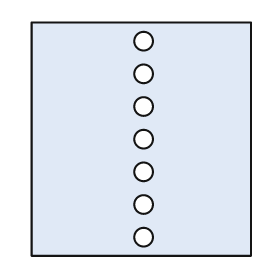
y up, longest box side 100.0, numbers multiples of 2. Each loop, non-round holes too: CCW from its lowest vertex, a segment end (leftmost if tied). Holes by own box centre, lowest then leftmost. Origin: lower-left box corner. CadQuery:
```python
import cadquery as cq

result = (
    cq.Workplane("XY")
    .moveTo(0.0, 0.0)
    .lineTo(94.0, 0.0)
    .lineTo(94.0, 100.0)
    .lineTo(0.0, 100.0)
    .close()
    .moveTo(48.0, 8.0)
    .circle(4.0)
    .moveTo(48.0, 22.0)
    .circle(4.0)
    .moveTo(48.0, 36.0)
    .circle(4.0)
    .moveTo(48.0, 50.0)
    .circle(4.0)
    .moveTo(48.0, 64.0)
    .circle(4.0)
    .moveTo(48.0, 78.0)
    .circle(4.0)
    .moveTo(48.0, 92.0)
    .circle(4.0)
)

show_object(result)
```